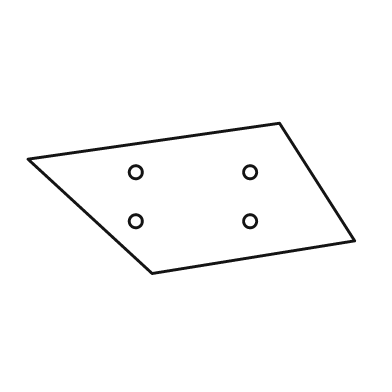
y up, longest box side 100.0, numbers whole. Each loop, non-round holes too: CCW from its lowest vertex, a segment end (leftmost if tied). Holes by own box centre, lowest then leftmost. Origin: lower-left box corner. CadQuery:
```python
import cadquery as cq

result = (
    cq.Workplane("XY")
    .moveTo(38.0, 0.0)
    .lineTo(100.0, 10.0)
    .lineTo(77.0, 46.0)
    .lineTo(0.0, 35.0)
    .close()
    .moveTo(33.0, 16.0)
    .circle(2.0)
    .moveTo(68.0, 16.0)
    .circle(2.0)
    .moveTo(33.0, 31.0)
    .circle(2.0)
    .moveTo(68.0, 31.0)
    .circle(2.0)
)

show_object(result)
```